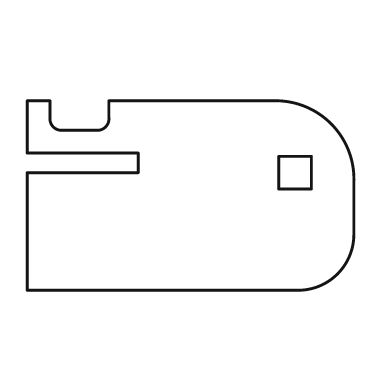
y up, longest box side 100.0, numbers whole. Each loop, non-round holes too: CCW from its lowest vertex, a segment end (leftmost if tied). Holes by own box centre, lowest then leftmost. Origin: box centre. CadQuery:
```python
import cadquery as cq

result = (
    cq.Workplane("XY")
    .moveTo(-50.0, -29.0)
    .lineTo(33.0, -29.0)
    .threePointArc((45.0, -24.0), (50.0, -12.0))
    .lineTo(50.0, 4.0)
    .threePointArc((43.0, 22.0), (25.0, 29.0))
    .lineTo(-25.0, 29.0)
    .lineTo(-25.0, 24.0)
    .threePointArc((-26.0, 21.0), (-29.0, 20.0))
    .lineTo(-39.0, 20.0)
    .threePointArc((-42.0, 21.0), (-43.0, 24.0))
    .lineTo(-43.0, 29.0)
    .lineTo(-50.0, 29.0)
    .lineTo(-50.0, 13.0)
    .lineTo(-16.0, 13.0)
    .lineTo(-16.0, 7.0)
    .lineTo(-50.0, 7.0)
    .close()
    .moveTo(27.0, 2.0)
    .lineTo(37.0, 2.0)
    .lineTo(37.0, 12.0)
    .lineTo(27.0, 12.0)
    .close()
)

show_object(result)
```